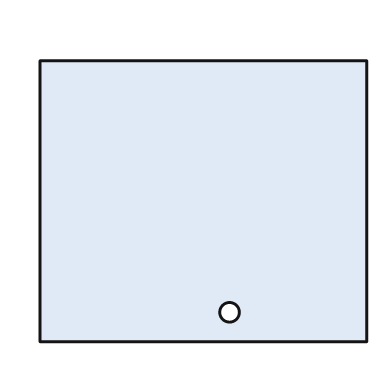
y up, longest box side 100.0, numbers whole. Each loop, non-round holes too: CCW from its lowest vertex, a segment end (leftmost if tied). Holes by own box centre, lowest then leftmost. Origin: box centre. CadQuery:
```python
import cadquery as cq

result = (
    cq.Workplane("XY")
    .moveTo(-50.0, -43.0)
    .lineTo(50.0, -43.0)
    .lineTo(50.0, 43.0)
    .lineTo(-50.0, 43.0)
    .close()
    .moveTo(8.0, -34.0)
    .circle(3.0)
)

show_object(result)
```